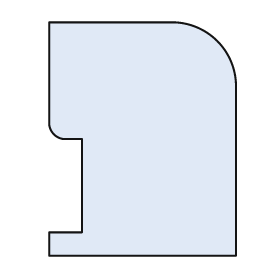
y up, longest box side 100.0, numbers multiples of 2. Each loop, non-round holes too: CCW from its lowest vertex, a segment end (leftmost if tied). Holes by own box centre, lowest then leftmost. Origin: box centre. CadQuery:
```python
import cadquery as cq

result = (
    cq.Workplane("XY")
    .moveTo(-40.0, -50.0)
    .lineTo(40.0, -50.0)
    .lineTo(40.0, 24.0)
    .threePointArc((32.0, 42.0), (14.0, 50.0))
    .lineTo(-40.0, 50.0)
    .lineTo(-40.0, 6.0)
    .threePointArc((-38.0, 2.0), (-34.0, 0.0))
    .lineTo(-26.0, 0.0)
    .lineTo(-26.0, -40.0)
    .lineTo(-40.0, -40.0)
    .close()
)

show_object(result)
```